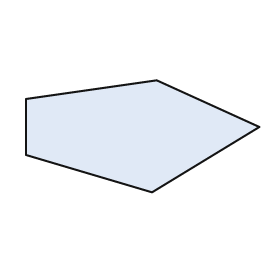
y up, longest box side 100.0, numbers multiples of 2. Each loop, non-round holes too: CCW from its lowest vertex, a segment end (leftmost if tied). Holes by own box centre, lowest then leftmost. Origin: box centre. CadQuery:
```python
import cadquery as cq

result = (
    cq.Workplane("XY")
    .moveTo(4.0, -24.0)
    .lineTo(50.0, 4.0)
    .lineTo(6.0, 24.0)
    .lineTo(-50.0, 16.0)
    .lineTo(-50.0, -8.0)
    .close()
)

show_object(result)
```